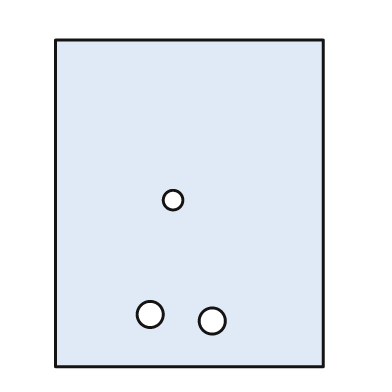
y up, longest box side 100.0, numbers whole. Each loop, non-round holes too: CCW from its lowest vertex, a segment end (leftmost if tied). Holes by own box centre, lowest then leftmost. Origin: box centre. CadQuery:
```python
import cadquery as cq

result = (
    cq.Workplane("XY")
    .moveTo(-41.0, -50.0)
    .lineTo(41.0, -50.0)
    .lineTo(41.0, 50.0)
    .lineTo(-41.0, 50.0)
    .close()
    .moveTo(7.0, -36.0)
    .circle(4.0)
    .moveTo(-12.0, -34.0)
    .circle(4.0)
    .moveTo(-5.0, 1.0)
    .circle(3.0)
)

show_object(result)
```